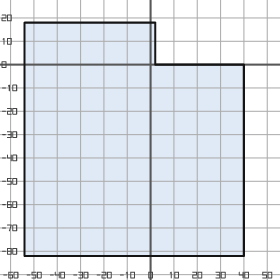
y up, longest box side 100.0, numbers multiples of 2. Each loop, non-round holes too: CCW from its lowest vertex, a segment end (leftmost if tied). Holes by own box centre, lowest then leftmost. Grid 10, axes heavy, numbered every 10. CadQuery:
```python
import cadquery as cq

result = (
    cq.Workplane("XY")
    .moveTo(-54.0, -82.0)
    .lineTo(40.0, -82.0)
    .lineTo(40.0, 0.0)
    .lineTo(2.0, 0.0)
    .lineTo(2.0, 18.0)
    .lineTo(-54.0, 18.0)
    .close()
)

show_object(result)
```